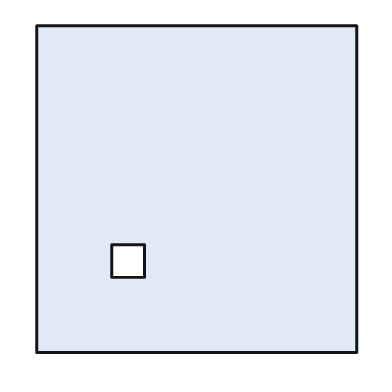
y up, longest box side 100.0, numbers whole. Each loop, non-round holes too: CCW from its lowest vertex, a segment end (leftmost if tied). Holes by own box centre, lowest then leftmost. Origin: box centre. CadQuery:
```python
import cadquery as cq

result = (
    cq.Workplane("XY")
    .moveTo(-49.0, -50.0)
    .lineTo(49.0, -50.0)
    .lineTo(49.0, 50.0)
    .lineTo(-49.0, 50.0)
    .close()
    .moveTo(-26.0, -27.0)
    .lineTo(-16.0, -27.0)
    .lineTo(-16.0, -17.0)
    .lineTo(-26.0, -17.0)
    .close()
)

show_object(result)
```